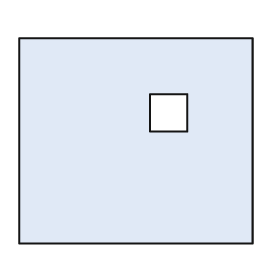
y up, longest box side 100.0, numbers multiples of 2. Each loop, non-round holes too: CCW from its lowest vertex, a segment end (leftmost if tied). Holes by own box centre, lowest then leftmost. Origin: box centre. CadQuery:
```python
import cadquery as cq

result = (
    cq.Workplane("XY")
    .moveTo(-50.0, -44.0)
    .lineTo(50.0, -44.0)
    .lineTo(50.0, 44.0)
    .lineTo(-50.0, 44.0)
    .close()
    .moveTo(6.0, 4.0)
    .lineTo(22.0, 4.0)
    .lineTo(22.0, 20.0)
    .lineTo(6.0, 20.0)
    .close()
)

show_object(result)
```